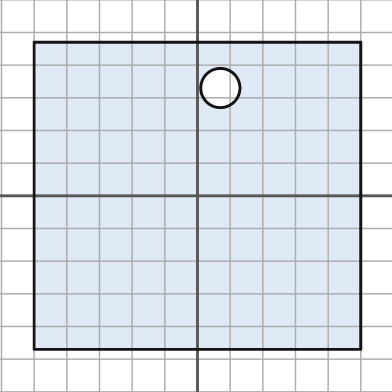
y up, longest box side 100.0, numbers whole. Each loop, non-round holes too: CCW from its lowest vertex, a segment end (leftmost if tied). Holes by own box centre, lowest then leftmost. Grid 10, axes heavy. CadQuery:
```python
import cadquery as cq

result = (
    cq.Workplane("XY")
    .moveTo(-50.0, -47.0)
    .lineTo(50.0, -47.0)
    .lineTo(50.0, 47.0)
    .lineTo(-50.0, 47.0)
    .close()
    .moveTo(7.0, 33.0)
    .circle(6.0)
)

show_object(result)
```